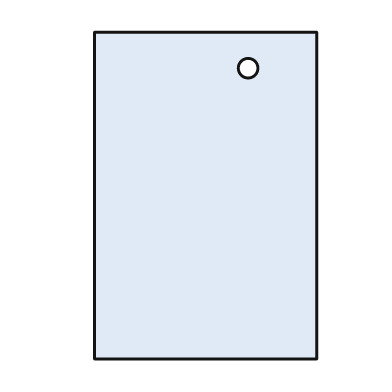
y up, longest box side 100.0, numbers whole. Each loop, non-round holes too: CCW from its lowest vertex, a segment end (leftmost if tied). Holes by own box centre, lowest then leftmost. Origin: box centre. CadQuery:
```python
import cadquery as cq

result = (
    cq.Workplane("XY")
    .moveTo(-34.0, -50.0)
    .lineTo(34.0, -50.0)
    .lineTo(34.0, 50.0)
    .lineTo(-34.0, 50.0)
    .close()
    .moveTo(13.0, 39.0)
    .circle(3.0)
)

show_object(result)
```